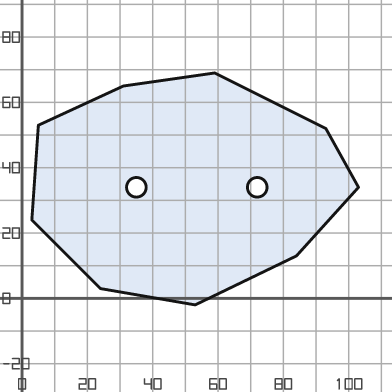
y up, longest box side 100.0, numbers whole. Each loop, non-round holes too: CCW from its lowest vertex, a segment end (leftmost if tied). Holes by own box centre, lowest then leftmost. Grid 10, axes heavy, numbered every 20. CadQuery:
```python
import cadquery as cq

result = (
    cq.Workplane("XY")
    .moveTo(53.0, -2.0)
    .lineTo(84.0, 13.0)
    .lineTo(103.0, 34.0)
    .lineTo(93.0, 52.0)
    .lineTo(59.0, 69.0)
    .lineTo(31.0, 65.0)
    .lineTo(5.0, 53.0)
    .lineTo(3.0, 24.0)
    .lineTo(24.0, 3.0)
    .close()
    .moveTo(35.0, 34.0)
    .circle(3.0)
    .moveTo(72.0, 34.0)
    .circle(3.0)
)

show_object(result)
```